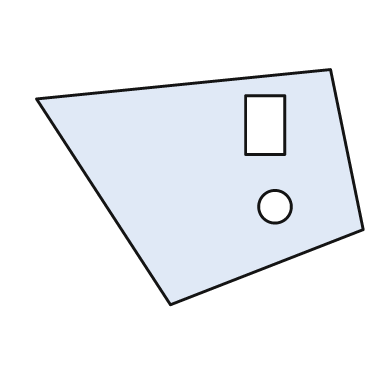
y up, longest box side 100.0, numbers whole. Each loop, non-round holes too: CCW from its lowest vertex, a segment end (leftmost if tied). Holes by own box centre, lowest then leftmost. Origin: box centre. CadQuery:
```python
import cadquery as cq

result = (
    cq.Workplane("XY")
    .moveTo(-9.0, -36.0)
    .lineTo(50.0, -13.0)
    .lineTo(40.0, 36.0)
    .lineTo(-50.0, 27.0)
    .close()
    .moveTo(23.0, -6.0)
    .circle(5.0)
    .moveTo(14.0, 10.0)
    .lineTo(26.0, 10.0)
    .lineTo(26.0, 28.0)
    .lineTo(14.0, 28.0)
    .close()
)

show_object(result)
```